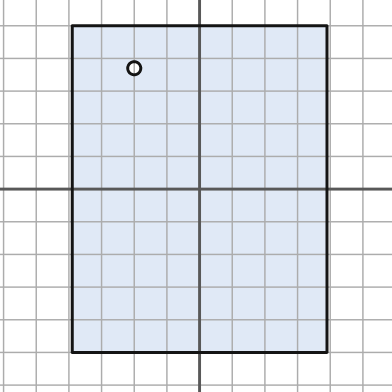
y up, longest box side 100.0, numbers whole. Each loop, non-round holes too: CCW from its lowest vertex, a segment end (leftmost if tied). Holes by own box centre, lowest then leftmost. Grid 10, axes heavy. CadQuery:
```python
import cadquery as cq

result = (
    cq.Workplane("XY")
    .moveTo(-39.0, -50.0)
    .lineTo(39.0, -50.0)
    .lineTo(39.0, 50.0)
    .lineTo(-39.0, 50.0)
    .close()
    .moveTo(-20.0, 37.0)
    .circle(2.0)
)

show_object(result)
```